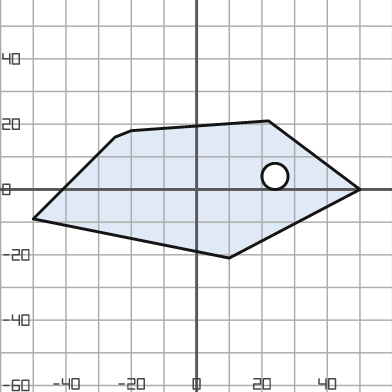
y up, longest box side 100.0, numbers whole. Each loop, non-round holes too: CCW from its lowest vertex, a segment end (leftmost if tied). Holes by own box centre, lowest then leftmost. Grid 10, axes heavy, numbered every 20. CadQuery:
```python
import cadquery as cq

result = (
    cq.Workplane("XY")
    .moveTo(10.0, -21.0)
    .lineTo(50.0, 0.0)
    .lineTo(22.0, 21.0)
    .lineTo(-20.0, 18.0)
    .lineTo(-25.0, 16.0)
    .lineTo(-50.0, -9.0)
    .close()
    .moveTo(24.0, 4.0)
    .circle(4.0)
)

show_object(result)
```